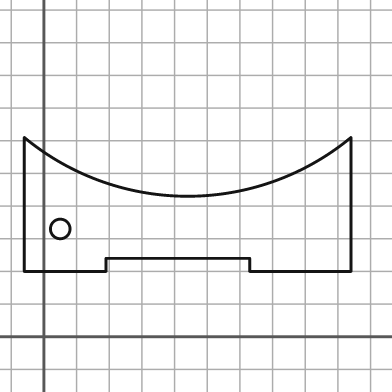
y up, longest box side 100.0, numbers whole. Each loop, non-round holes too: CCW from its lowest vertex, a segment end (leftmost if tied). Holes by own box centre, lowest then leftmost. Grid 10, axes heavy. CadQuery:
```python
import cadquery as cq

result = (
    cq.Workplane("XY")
    .moveTo(-6.0, 20.0)
    .lineTo(19.0, 20.0)
    .lineTo(19.0, 24.0)
    .lineTo(63.0, 24.0)
    .lineTo(63.0, 20.0)
    .lineTo(94.0, 20.0)
    .lineTo(94.0, 61.0)
    .threePointArc((44.0, 43.0), (-6.0, 61.0))
    .close()
    .moveTo(5.0, 33.0)
    .circle(3.0)
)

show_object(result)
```